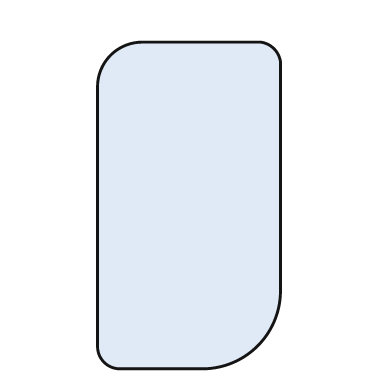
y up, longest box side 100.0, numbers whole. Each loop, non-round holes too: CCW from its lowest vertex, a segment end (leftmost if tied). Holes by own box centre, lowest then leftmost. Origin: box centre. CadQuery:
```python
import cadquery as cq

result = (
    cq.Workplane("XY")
    .moveTo(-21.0, -50.0)
    .lineTo(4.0, -50.0)
    .threePointArc((21.0, -43.0), (28.0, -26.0))
    .lineTo(28.0, 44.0)
    .threePointArc((26.0, 48.0), (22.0, 50.0))
    .lineTo(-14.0, 50.0)
    .threePointArc((-24.0, 46.0), (-28.0, 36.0))
    .lineTo(-28.0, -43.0)
    .threePointArc((-26.0, -48.0), (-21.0, -50.0))
    .close()
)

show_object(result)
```